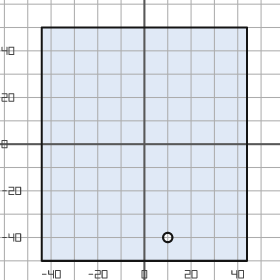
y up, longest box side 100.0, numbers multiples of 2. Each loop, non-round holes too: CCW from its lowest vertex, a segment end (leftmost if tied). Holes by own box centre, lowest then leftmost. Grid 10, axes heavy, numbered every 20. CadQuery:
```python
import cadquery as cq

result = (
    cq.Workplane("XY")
    .moveTo(-44.0, -50.0)
    .lineTo(44.0, -50.0)
    .lineTo(44.0, 50.0)
    .lineTo(-44.0, 50.0)
    .close()
    .moveTo(10.0, -40.0)
    .circle(2.0)
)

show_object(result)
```